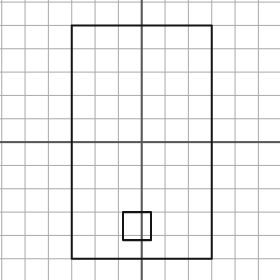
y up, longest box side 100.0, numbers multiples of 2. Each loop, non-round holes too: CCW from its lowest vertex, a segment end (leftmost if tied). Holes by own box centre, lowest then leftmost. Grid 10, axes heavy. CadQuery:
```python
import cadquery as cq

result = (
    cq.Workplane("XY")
    .moveTo(-30.0, -50.0)
    .lineTo(30.0, -50.0)
    .lineTo(30.0, 50.0)
    .lineTo(-30.0, 50.0)
    .close()
    .moveTo(-8.0, -42.0)
    .lineTo(4.0, -42.0)
    .lineTo(4.0, -30.0)
    .lineTo(-8.0, -30.0)
    .close()
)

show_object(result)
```